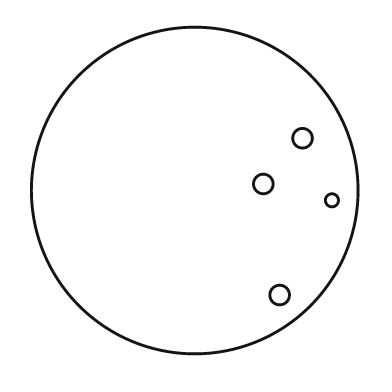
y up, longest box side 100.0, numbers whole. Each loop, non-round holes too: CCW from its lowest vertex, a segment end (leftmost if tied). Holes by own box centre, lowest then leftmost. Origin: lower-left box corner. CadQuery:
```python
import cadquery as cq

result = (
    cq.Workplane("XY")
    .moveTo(50.0, 50.0)
    .circle(50.0)
    .moveTo(76.0, 18.0)
    .circle(3.0)
    .moveTo(92.0, 47.0)
    .circle(2.0)
    .moveTo(71.0, 52.0)
    .circle(3.0)
    .moveTo(83.0, 66.0)
    .circle(3.0)
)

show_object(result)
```